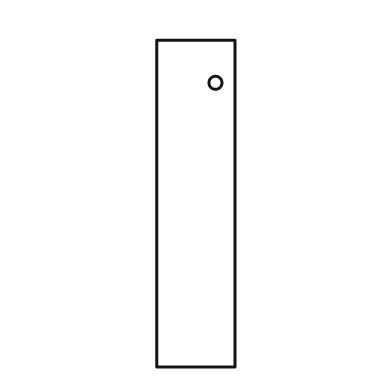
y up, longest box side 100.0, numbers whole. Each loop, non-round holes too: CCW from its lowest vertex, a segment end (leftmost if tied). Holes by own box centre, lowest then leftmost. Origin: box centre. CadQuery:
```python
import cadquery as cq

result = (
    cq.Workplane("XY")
    .moveTo(-12.0, -50.0)
    .lineTo(12.0, -50.0)
    .lineTo(12.0, 50.0)
    .lineTo(-12.0, 50.0)
    .close()
    .moveTo(6.0, 37.0)
    .circle(2.0)
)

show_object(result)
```